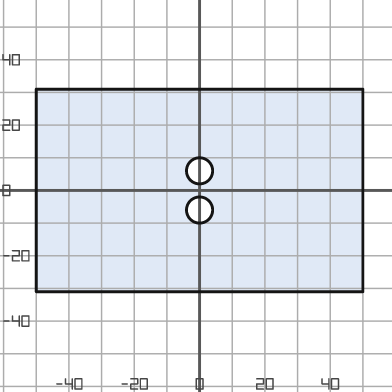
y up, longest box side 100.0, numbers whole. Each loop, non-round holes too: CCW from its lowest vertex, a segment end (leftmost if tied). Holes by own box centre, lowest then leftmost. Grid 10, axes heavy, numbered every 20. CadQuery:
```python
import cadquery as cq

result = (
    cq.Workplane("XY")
    .moveTo(-50.0, -31.0)
    .lineTo(50.0, -31.0)
    .lineTo(50.0, 31.0)
    .lineTo(-50.0, 31.0)
    .close()
    .moveTo(0.0, -6.0)
    .circle(4.0)
    .moveTo(0.0, 6.0)
    .circle(4.0)
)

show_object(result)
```